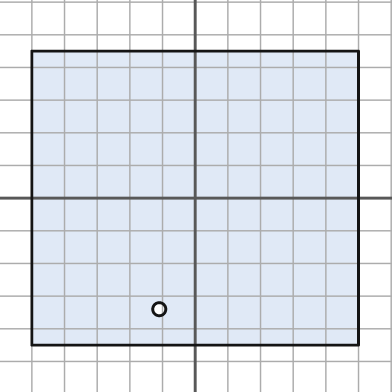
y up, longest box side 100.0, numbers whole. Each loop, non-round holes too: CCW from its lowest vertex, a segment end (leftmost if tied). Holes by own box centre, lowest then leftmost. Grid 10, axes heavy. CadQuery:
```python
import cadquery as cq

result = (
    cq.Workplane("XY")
    .moveTo(-50.0, -45.0)
    .lineTo(50.0, -45.0)
    .lineTo(50.0, 45.0)
    .lineTo(-50.0, 45.0)
    .close()
    .moveTo(-11.0, -34.0)
    .circle(2.0)
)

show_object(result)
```